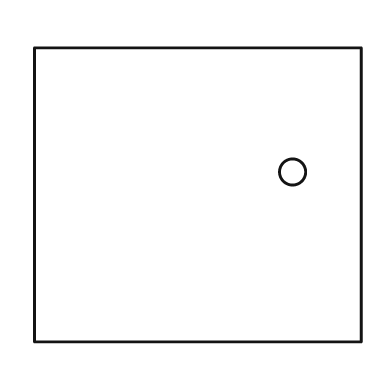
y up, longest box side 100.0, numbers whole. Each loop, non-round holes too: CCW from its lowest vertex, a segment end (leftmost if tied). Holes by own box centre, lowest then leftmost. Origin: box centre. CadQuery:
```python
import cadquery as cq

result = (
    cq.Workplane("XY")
    .moveTo(-50.0, -45.0)
    .lineTo(50.0, -45.0)
    .lineTo(50.0, 45.0)
    .lineTo(-50.0, 45.0)
    .close()
    .moveTo(29.0, 7.0)
    .circle(4.0)
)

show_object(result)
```